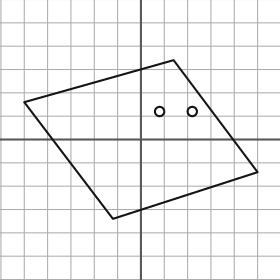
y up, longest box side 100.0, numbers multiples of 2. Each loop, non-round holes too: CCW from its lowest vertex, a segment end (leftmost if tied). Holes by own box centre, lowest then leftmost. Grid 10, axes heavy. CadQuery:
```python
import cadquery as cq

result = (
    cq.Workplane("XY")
    .moveTo(-12.0, -34.0)
    .lineTo(50.0, -14.0)
    .lineTo(14.0, 34.0)
    .lineTo(-50.0, 16.0)
    .close()
    .moveTo(8.0, 12.0)
    .circle(2.0)
    .moveTo(22.0, 12.0)
    .circle(2.0)
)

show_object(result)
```